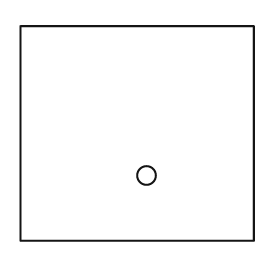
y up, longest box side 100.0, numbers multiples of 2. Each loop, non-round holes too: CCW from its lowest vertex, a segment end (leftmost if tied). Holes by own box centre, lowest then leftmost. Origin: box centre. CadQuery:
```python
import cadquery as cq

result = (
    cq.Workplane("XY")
    .moveTo(-50.0, -46.0)
    .lineTo(50.0, -46.0)
    .lineTo(50.0, 46.0)
    .lineTo(-50.0, 46.0)
    .close()
    .moveTo(4.0, -18.0)
    .circle(4.0)
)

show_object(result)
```